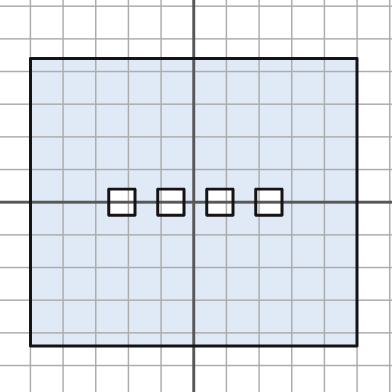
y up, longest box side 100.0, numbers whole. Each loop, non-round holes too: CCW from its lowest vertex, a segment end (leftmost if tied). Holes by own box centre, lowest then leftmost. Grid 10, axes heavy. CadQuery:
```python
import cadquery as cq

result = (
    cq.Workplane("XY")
    .moveTo(-50.0, -44.0)
    .lineTo(50.0, -44.0)
    .lineTo(50.0, 44.0)
    .lineTo(-50.0, 44.0)
    .close()
    .moveTo(-26.0, -4.0)
    .lineTo(-18.0, -4.0)
    .lineTo(-18.0, 4.0)
    .lineTo(-26.0, 4.0)
    .close()
    .moveTo(-11.0, -4.0)
    .lineTo(-3.0, -4.0)
    .lineTo(-3.0, 4.0)
    .lineTo(-11.0, 4.0)
    .close()
    .moveTo(4.0, -4.0)
    .lineTo(12.0, -4.0)
    .lineTo(12.0, 4.0)
    .lineTo(4.0, 4.0)
    .close()
    .moveTo(19.0, -4.0)
    .lineTo(27.0, -4.0)
    .lineTo(27.0, 4.0)
    .lineTo(19.0, 4.0)
    .close()
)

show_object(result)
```